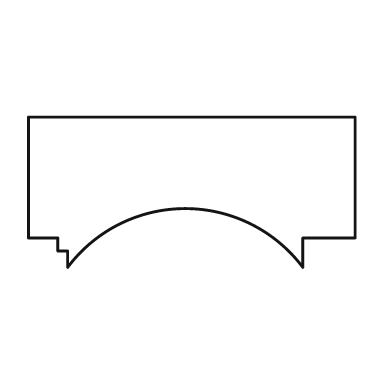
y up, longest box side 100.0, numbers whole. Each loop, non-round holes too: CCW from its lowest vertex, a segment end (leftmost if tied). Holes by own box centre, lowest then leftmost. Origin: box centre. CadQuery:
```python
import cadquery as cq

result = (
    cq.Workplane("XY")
    .moveTo(-38.0, -23.0)
    .threePointArc((-2.0, -5.0), (34.0, -23.0))
    .lineTo(34.0, -14.0)
    .lineTo(50.0, -14.0)
    .lineTo(50.0, 23.0)
    .lineTo(-50.0, 23.0)
    .lineTo(-50.0, -14.0)
    .lineTo(-41.0, -14.0)
    .lineTo(-41.0, -18.0)
    .lineTo(-38.0, -18.0)
    .close()
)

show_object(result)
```